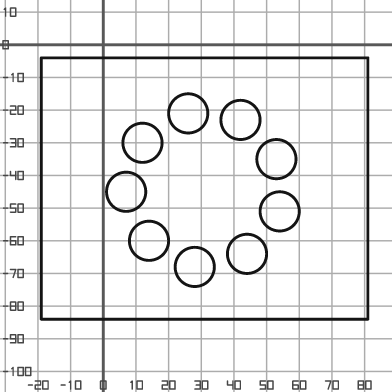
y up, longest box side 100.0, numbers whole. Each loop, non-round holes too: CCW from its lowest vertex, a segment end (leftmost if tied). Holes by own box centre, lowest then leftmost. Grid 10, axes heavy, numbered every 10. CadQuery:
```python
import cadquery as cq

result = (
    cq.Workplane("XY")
    .moveTo(-19.0, -84.0)
    .lineTo(81.0, -84.0)
    .lineTo(81.0, -4.0)
    .lineTo(-19.0, -4.0)
    .close()
    .moveTo(28.0, -68.0)
    .circle(6.0)
    .moveTo(44.0, -64.0)
    .circle(6.0)
    .moveTo(14.0, -60.0)
    .circle(6.0)
    .moveTo(54.0, -51.0)
    .circle(6.0)
    .moveTo(7.0, -45.0)
    .circle(6.0)
    .moveTo(53.0, -35.0)
    .circle(6.0)
    .moveTo(12.0, -30.0)
    .circle(6.0)
    .moveTo(42.0, -23.0)
    .circle(6.0)
    .moveTo(26.0, -21.0)
    .circle(6.0)
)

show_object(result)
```